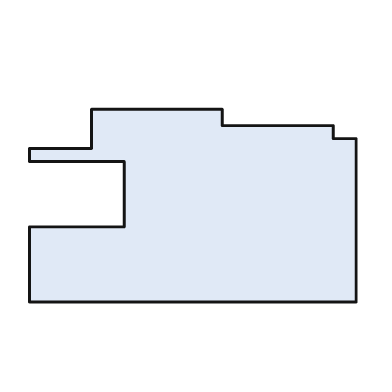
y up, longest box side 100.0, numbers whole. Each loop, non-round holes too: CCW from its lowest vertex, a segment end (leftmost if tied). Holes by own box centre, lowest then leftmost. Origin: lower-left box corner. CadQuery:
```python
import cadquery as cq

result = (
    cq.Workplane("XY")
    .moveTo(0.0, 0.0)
    .lineTo(100.0, 0.0)
    .lineTo(100.0, 50.0)
    .lineTo(93.0, 50.0)
    .lineTo(93.0, 54.0)
    .lineTo(59.0, 54.0)
    .lineTo(59.0, 59.0)
    .lineTo(19.0, 59.0)
    .lineTo(19.0, 47.0)
    .lineTo(0.0, 47.0)
    .lineTo(0.0, 43.0)
    .lineTo(29.0, 43.0)
    .lineTo(29.0, 23.0)
    .lineTo(0.0, 23.0)
    .close()
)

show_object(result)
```